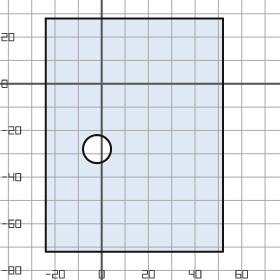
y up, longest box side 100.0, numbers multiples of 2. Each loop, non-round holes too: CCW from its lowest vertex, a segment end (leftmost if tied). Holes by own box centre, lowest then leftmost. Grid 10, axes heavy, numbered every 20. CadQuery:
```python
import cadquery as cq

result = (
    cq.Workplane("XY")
    .moveTo(-24.0, -72.0)
    .lineTo(52.0, -72.0)
    .lineTo(52.0, 28.0)
    .lineTo(-24.0, 28.0)
    .close()
    .moveTo(-2.0, -28.0)
    .circle(6.0)
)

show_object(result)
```